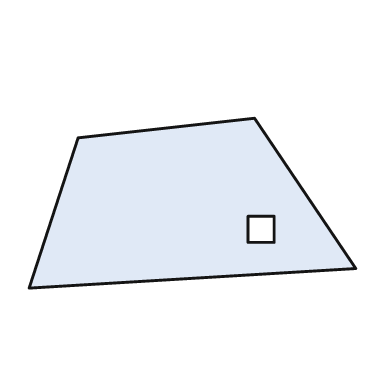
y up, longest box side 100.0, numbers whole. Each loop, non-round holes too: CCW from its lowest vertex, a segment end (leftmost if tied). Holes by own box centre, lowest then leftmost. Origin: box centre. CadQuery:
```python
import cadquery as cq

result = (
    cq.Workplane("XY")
    .moveTo(-50.0, -26.0)
    .lineTo(50.0, -20.0)
    .lineTo(19.0, 26.0)
    .lineTo(-35.0, 20.0)
    .close()
    .moveTo(17.0, -12.0)
    .lineTo(25.0, -12.0)
    .lineTo(25.0, -4.0)
    .lineTo(17.0, -4.0)
    .close()
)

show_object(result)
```